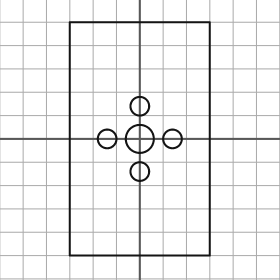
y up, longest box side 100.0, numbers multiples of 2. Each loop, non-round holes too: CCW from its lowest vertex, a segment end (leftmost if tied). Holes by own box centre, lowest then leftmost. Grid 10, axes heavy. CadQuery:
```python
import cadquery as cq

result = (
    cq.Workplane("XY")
    .moveTo(-30.0, -50.0)
    .lineTo(30.0, -50.0)
    .lineTo(30.0, 50.0)
    .lineTo(-30.0, 50.0)
    .close()
    .moveTo(0.0, -14.0)
    .circle(4.0)
    .moveTo(-14.0, 0.0)
    .circle(4.0)
    .moveTo(0.0, 0.0)
    .circle(6.0)
    .moveTo(14.0, 0.0)
    .circle(4.0)
    .moveTo(0.0, 14.0)
    .circle(4.0)
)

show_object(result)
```